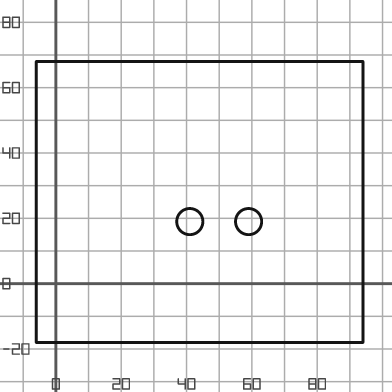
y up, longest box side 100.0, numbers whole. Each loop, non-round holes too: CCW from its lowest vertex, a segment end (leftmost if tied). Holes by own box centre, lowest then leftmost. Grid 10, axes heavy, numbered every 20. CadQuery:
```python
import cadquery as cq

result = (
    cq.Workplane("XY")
    .moveTo(-6.0, -18.0)
    .lineTo(94.0, -18.0)
    .lineTo(94.0, 68.0)
    .lineTo(-6.0, 68.0)
    .close()
    .moveTo(41.0, 19.0)
    .circle(4.0)
    .moveTo(59.0, 19.0)
    .circle(4.0)
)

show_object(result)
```